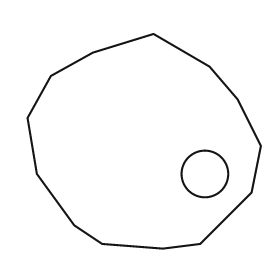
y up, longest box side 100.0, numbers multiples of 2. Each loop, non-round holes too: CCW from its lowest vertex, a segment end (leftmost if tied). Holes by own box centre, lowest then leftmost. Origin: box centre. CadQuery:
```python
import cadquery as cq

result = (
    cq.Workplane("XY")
    .moveTo(8.0, -46.0)
    .lineTo(24.0, -44.0)
    .lineTo(46.0, -22.0)
    .lineTo(50.0, -2.0)
    .lineTo(40.0, 18.0)
    .lineTo(28.0, 32.0)
    .lineTo(4.0, 46.0)
    .lineTo(-22.0, 38.0)
    .lineTo(-40.0, 28.0)
    .lineTo(-50.0, 10.0)
    .lineTo(-46.0, -14.0)
    .lineTo(-30.0, -36.0)
    .lineTo(-18.0, -44.0)
    .close()
    .moveTo(26.0, -14.0)
    .circle(10.0)
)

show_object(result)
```